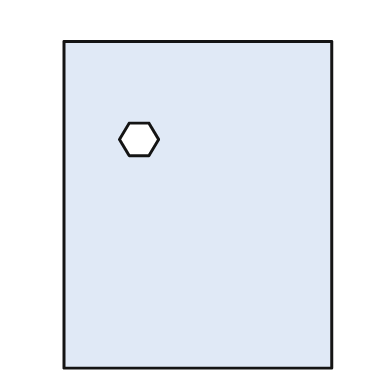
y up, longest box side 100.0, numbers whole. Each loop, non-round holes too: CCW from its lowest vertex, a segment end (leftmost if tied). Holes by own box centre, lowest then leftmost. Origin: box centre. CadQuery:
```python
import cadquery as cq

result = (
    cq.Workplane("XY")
    .moveTo(-41.0, -50.0)
    .lineTo(41.0, -50.0)
    .lineTo(41.0, 50.0)
    .lineTo(-41.0, 50.0)
    .close()
    .moveTo(-21.0, 15.0)
    .lineTo(-15.0, 15.0)
    .lineTo(-12.0, 20.0)
    .lineTo(-15.0, 25.0)
    .lineTo(-21.0, 25.0)
    .lineTo(-24.0, 20.0)
    .close()
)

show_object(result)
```